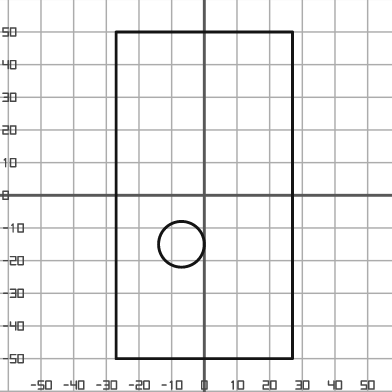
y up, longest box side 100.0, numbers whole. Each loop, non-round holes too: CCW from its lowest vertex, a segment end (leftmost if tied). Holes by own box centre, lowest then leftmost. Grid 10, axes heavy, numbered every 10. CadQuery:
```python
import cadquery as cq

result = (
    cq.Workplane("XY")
    .moveTo(-27.0, -50.0)
    .lineTo(27.0, -50.0)
    .lineTo(27.0, 50.0)
    .lineTo(-27.0, 50.0)
    .close()
    .moveTo(-7.0, -15.0)
    .circle(7.0)
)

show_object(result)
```